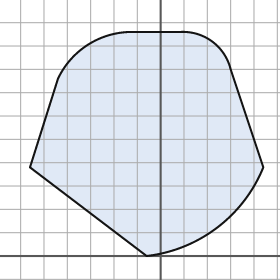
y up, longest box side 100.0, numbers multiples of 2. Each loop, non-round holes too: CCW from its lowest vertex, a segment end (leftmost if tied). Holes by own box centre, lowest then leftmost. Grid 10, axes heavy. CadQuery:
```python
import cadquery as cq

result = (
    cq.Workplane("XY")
    .moveTo(-6.0, 0.0)
    .threePointArc((24.0, 12.0), (44.0, 38.0))
    .lineTo(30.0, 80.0)
    .threePointArc((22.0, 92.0), (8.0, 96.0))
    .lineTo(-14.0, 96.0)
    .threePointArc((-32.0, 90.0), (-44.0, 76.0))
    .lineTo(-56.0, 38.0)
    .close()
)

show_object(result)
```